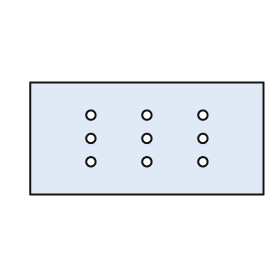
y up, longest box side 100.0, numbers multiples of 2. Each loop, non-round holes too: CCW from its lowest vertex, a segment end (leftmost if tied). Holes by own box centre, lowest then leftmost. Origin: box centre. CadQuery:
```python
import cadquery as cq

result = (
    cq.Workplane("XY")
    .moveTo(-50.0, -24.0)
    .lineTo(50.0, -24.0)
    .lineTo(50.0, 24.0)
    .lineTo(-50.0, 24.0)
    .close()
    .moveTo(-24.0, -10.0)
    .circle(2.0)
    .moveTo(0.0, -10.0)
    .circle(2.0)
    .moveTo(24.0, -10.0)
    .circle(2.0)
    .moveTo(-24.0, 0.0)
    .circle(2.0)
    .moveTo(0.0, 0.0)
    .circle(2.0)
    .moveTo(24.0, 0.0)
    .circle(2.0)
    .moveTo(-24.0, 10.0)
    .circle(2.0)
    .moveTo(0.0, 10.0)
    .circle(2.0)
    .moveTo(24.0, 10.0)
    .circle(2.0)
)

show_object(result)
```